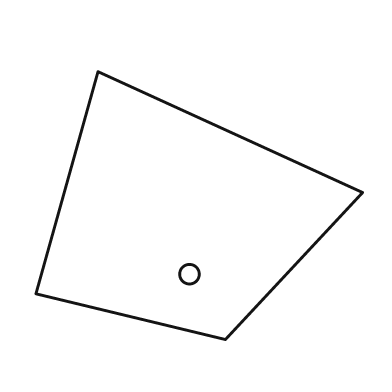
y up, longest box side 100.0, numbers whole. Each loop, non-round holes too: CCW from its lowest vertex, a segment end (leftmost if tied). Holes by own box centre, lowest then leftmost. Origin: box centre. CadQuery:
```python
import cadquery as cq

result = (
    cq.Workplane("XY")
    .moveTo(8.0, -41.0)
    .lineTo(50.0, 4.0)
    .lineTo(-31.0, 41.0)
    .lineTo(-50.0, -27.0)
    .close()
    .moveTo(-3.0, -21.0)
    .circle(3.0)
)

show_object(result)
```